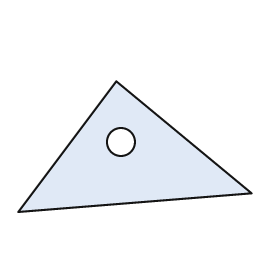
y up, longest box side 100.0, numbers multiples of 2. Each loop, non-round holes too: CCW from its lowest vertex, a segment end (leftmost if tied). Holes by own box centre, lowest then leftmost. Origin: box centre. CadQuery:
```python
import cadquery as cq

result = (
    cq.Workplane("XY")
    .moveTo(-50.0, -28.0)
    .lineTo(50.0, -20.0)
    .lineTo(-8.0, 28.0)
    .close()
    .moveTo(-6.0, 2.0)
    .circle(6.0)
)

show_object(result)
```